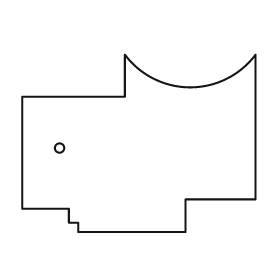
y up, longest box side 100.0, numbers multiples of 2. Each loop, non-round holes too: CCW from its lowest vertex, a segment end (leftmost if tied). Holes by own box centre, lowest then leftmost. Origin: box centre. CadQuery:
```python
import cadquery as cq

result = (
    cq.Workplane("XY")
    .moveTo(-26.0, -38.0)
    .lineTo(20.0, -38.0)
    .lineTo(20.0, -24.0)
    .lineTo(50.0, -24.0)
    .lineTo(50.0, 38.0)
    .threePointArc((22.0, 24.0), (-6.0, 38.0))
    .lineTo(-6.0, 20.0)
    .lineTo(-50.0, 20.0)
    .lineTo(-50.0, -28.0)
    .lineTo(-30.0, -28.0)
    .lineTo(-30.0, -34.0)
    .lineTo(-26.0, -34.0)
    .close()
    .moveTo(-34.0, -2.0)
    .circle(2.0)
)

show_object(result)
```